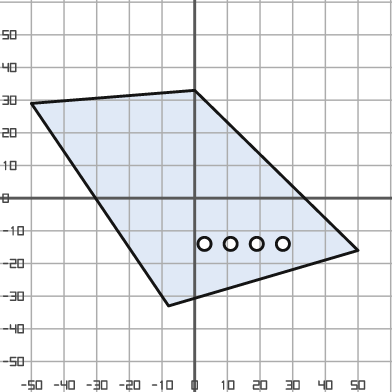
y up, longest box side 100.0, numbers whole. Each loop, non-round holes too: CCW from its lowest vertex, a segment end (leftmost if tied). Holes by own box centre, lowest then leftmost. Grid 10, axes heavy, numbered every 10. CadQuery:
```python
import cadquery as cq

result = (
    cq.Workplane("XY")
    .moveTo(-8.0, -33.0)
    .lineTo(50.0, -16.0)
    .lineTo(0.0, 33.0)
    .lineTo(-50.0, 29.0)
    .close()
    .moveTo(3.0, -14.0)
    .circle(2.0)
    .moveTo(11.0, -14.0)
    .circle(2.0)
    .moveTo(19.0, -14.0)
    .circle(2.0)
    .moveTo(27.0, -14.0)
    .circle(2.0)
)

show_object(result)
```